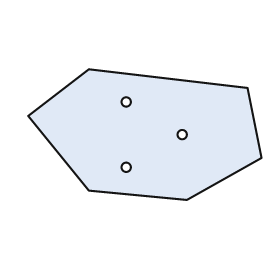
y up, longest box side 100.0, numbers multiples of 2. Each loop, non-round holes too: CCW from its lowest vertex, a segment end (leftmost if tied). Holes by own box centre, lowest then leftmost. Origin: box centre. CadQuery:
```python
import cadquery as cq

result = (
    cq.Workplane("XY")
    .moveTo(18.0, -28.0)
    .lineTo(50.0, -10.0)
    .lineTo(44.0, 20.0)
    .lineTo(-24.0, 28.0)
    .lineTo(-50.0, 8.0)
    .lineTo(-24.0, -24.0)
    .close()
    .moveTo(-8.0, -14.0)
    .circle(2.0)
    .moveTo(16.0, 0.0)
    .circle(2.0)
    .moveTo(-8.0, 14.0)
    .circle(2.0)
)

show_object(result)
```